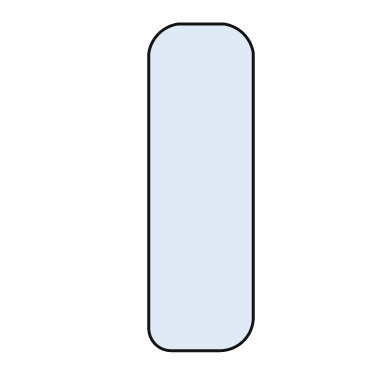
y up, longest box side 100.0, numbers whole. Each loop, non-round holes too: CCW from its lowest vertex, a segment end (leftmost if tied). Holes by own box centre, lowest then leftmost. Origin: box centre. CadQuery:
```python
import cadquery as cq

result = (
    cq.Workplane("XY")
    .moveTo(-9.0, -50.0)
    .lineTo(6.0, -50.0)
    .threePointArc((13.0, -47.0), (16.0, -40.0))
    .lineTo(16.0, 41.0)
    .threePointArc((13.0, 47.0), (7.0, 50.0))
    .lineTo(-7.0, 50.0)
    .threePointArc((-13.0, 47.0), (-16.0, 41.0))
    .lineTo(-16.0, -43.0)
    .threePointArc((-14.0, -48.0), (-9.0, -50.0))
    .close()
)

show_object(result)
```